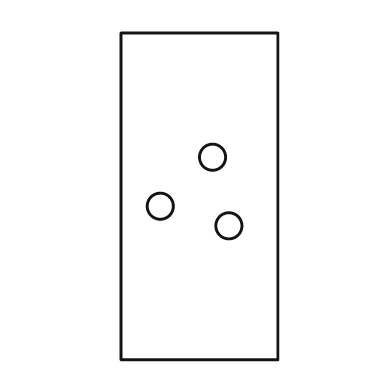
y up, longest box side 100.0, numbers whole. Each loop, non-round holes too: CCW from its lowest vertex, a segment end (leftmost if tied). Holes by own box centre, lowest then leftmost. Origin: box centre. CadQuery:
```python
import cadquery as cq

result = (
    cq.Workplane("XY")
    .moveTo(-24.0, -50.0)
    .lineTo(24.0, -50.0)
    .lineTo(24.0, 50.0)
    .lineTo(-24.0, 50.0)
    .close()
    .moveTo(9.0, -9.0)
    .circle(4.0)
    .moveTo(-12.0, -3.0)
    .circle(4.0)
    .moveTo(4.0, 12.0)
    .circle(4.0)
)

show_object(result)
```